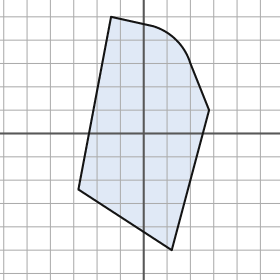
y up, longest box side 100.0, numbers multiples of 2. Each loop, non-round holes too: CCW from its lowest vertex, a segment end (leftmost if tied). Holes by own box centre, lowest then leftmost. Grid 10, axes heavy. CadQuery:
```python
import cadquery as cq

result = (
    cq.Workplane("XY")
    .moveTo(12.0, -50.0)
    .lineTo(28.0, 10.0)
    .lineTo(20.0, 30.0)
    .threePointArc((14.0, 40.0), (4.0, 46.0))
    .lineTo(-14.0, 50.0)
    .lineTo(-28.0, -24.0)
    .close()
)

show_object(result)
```